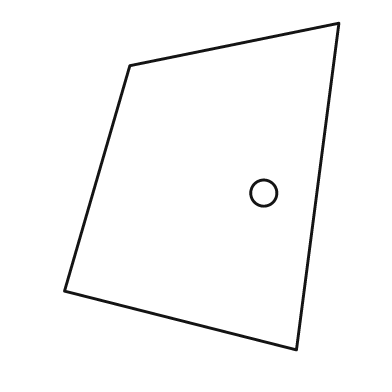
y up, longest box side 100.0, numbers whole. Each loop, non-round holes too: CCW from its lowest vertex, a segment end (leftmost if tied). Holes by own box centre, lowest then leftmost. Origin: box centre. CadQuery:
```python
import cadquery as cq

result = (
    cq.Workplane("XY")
    .moveTo(29.0, -50.0)
    .lineTo(42.0, 50.0)
    .lineTo(-22.0, 37.0)
    .lineTo(-42.0, -32.0)
    .close()
    .moveTo(19.0, -2.0)
    .circle(4.0)
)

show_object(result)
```